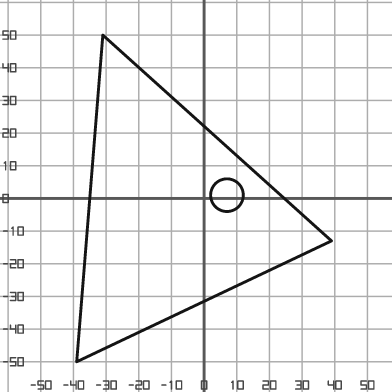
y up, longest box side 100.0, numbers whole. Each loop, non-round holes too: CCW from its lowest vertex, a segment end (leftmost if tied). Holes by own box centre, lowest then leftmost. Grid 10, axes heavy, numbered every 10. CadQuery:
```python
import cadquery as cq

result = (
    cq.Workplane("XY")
    .moveTo(-39.0, -50.0)
    .lineTo(39.0, -13.0)
    .lineTo(-31.0, 50.0)
    .close()
    .moveTo(7.0, 1.0)
    .circle(5.0)
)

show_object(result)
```